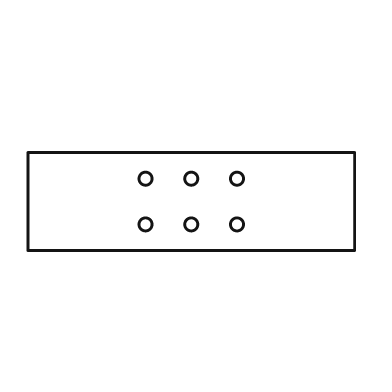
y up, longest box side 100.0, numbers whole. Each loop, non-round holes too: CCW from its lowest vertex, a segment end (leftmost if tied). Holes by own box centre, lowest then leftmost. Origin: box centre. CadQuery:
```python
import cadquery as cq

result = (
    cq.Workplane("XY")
    .moveTo(-50.0, -15.0)
    .lineTo(50.0, -15.0)
    .lineTo(50.0, 15.0)
    .lineTo(-50.0, 15.0)
    .close()
    .moveTo(-14.0, -7.0)
    .circle(2.0)
    .moveTo(0.0, -7.0)
    .circle(2.0)
    .moveTo(14.0, -7.0)
    .circle(2.0)
    .moveTo(-14.0, 7.0)
    .circle(2.0)
    .moveTo(0.0, 7.0)
    .circle(2.0)
    .moveTo(14.0, 7.0)
    .circle(2.0)
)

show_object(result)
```